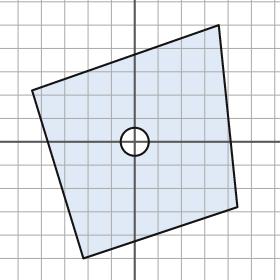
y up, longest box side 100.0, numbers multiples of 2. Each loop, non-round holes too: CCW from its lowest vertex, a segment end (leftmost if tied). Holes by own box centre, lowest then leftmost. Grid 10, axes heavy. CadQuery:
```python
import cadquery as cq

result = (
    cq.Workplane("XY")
    .moveTo(-22.0, -50.0)
    .lineTo(44.0, -28.0)
    .lineTo(36.0, 50.0)
    .lineTo(-44.0, 22.0)
    .close()
    .moveTo(0.0, 0.0)
    .circle(6.0)
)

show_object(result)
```